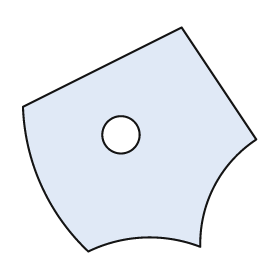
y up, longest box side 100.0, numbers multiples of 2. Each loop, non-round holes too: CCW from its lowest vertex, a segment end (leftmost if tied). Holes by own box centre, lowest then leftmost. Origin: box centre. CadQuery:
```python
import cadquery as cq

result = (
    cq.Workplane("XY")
    .moveTo(-22.0, -48.0)
    .threePointArc((2.0, -42.0), (26.0, -46.0))
    .threePointArc((32.0, -20.0), (50.0, 0.0))
    .lineTo(18.0, 48.0)
    .lineTo(-50.0, 14.0)
    .threePointArc((-42.0, -20.0), (-22.0, -48.0))
    .close()
    .moveTo(-8.0, 2.0)
    .circle(8.0)
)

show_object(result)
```